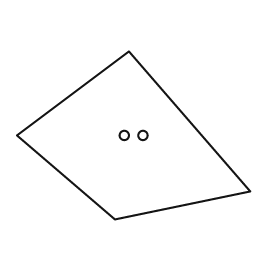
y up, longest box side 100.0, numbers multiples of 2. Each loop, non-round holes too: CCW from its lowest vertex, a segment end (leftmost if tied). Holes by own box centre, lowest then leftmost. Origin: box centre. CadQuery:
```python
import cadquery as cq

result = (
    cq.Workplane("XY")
    .moveTo(-8.0, -36.0)
    .lineTo(50.0, -24.0)
    .lineTo(-2.0, 36.0)
    .lineTo(-50.0, 0.0)
    .close()
    .moveTo(-4.0, 0.0)
    .circle(2.0)
    .moveTo(4.0, 0.0)
    .circle(2.0)
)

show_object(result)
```